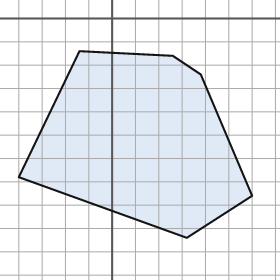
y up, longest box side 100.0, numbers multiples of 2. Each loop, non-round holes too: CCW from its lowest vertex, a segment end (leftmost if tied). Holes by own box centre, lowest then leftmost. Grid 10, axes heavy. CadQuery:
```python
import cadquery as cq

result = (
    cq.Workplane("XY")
    .moveTo(32.0, -94.0)
    .lineTo(60.0, -76.0)
    .lineTo(38.0, -24.0)
    .lineTo(26.0, -16.0)
    .lineTo(-14.0, -14.0)
    .lineTo(-40.0, -68.0)
    .close()
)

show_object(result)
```